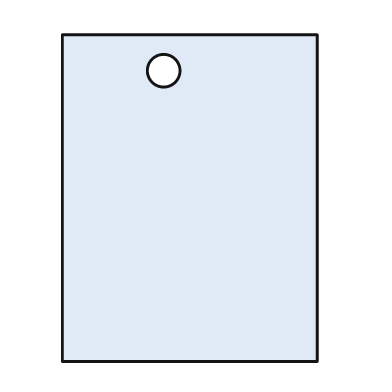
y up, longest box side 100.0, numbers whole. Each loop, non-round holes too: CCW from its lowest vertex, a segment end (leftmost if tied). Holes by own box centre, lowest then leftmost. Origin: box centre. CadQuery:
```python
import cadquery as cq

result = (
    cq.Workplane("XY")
    .moveTo(-39.0, -50.0)
    .lineTo(39.0, -50.0)
    .lineTo(39.0, 50.0)
    .lineTo(-39.0, 50.0)
    .close()
    .moveTo(-8.0, 39.0)
    .circle(5.0)
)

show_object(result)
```